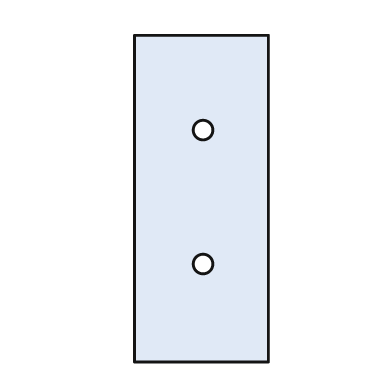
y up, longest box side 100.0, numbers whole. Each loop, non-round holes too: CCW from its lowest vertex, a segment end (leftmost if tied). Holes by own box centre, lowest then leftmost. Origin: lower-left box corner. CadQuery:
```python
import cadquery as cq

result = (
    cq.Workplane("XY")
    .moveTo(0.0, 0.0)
    .lineTo(41.0, 0.0)
    .lineTo(41.0, 100.0)
    .lineTo(0.0, 100.0)
    .close()
    .moveTo(21.0, 30.0)
    .circle(3.0)
    .moveTo(21.0, 71.0)
    .circle(3.0)
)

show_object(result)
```